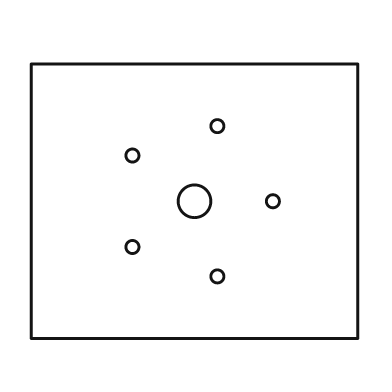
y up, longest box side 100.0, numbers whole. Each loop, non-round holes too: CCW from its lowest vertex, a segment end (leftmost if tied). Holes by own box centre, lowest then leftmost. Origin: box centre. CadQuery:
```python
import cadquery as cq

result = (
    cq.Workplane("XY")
    .moveTo(-50.0, -42.0)
    .lineTo(50.0, -42.0)
    .lineTo(50.0, 42.0)
    .lineTo(-50.0, 42.0)
    .close()
    .moveTo(7.0, -23.0)
    .circle(2.0)
    .moveTo(-19.0, -14.0)
    .circle(2.0)
    .moveTo(0.0, 0.0)
    .circle(5.0)
    .moveTo(24.0, 0.0)
    .circle(2.0)
    .moveTo(-19.0, 14.0)
    .circle(2.0)
    .moveTo(7.0, 23.0)
    .circle(2.0)
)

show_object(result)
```